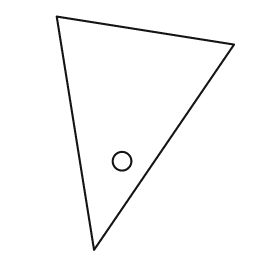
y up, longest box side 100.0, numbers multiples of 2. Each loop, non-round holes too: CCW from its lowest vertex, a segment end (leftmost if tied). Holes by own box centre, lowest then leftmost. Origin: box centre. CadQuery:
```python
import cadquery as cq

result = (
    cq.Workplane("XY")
    .moveTo(-22.0, -50.0)
    .lineTo(38.0, 38.0)
    .lineTo(-38.0, 50.0)
    .close()
    .moveTo(-10.0, -12.0)
    .circle(4.0)
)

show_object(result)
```